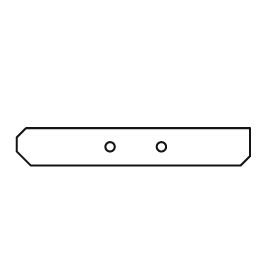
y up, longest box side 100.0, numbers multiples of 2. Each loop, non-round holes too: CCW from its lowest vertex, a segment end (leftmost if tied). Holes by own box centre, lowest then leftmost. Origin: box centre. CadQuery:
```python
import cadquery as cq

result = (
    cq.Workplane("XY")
    .moveTo(-44.0, -8.0)
    .lineTo(46.0, -8.0)
    .lineTo(50.0, -4.0)
    .lineTo(50.0, 8.0)
    .lineTo(-46.0, 8.0)
    .lineTo(-50.0, 4.0)
    .lineTo(-50.0, -2.0)
    .close()
    .moveTo(-10.0, 0.0)
    .circle(2.0)
    .moveTo(12.0, 0.0)
    .circle(2.0)
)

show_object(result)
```